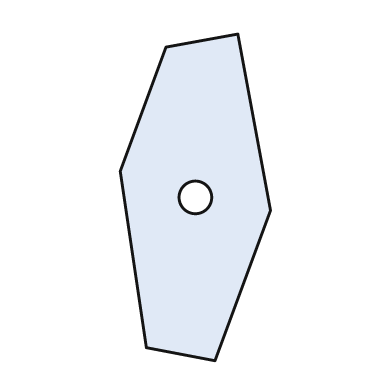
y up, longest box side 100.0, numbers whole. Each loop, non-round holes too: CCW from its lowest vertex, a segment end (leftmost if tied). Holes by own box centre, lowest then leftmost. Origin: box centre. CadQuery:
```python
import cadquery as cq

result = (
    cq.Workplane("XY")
    .moveTo(6.0, -50.0)
    .lineTo(23.0, -4.0)
    .lineTo(13.0, 50.0)
    .lineTo(-9.0, 46.0)
    .lineTo(-23.0, 8.0)
    .lineTo(-15.0, -46.0)
    .close()
    .moveTo(0.0, 0.0)
    .circle(5.0)
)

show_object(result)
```